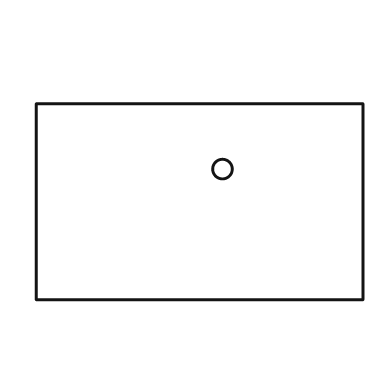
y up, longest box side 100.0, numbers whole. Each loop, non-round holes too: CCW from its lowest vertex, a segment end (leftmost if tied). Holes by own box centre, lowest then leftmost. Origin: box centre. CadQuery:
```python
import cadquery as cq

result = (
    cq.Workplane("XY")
    .moveTo(-50.0, -30.0)
    .lineTo(50.0, -30.0)
    .lineTo(50.0, 30.0)
    .lineTo(-50.0, 30.0)
    .close()
    .moveTo(7.0, 10.0)
    .circle(3.0)
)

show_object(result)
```